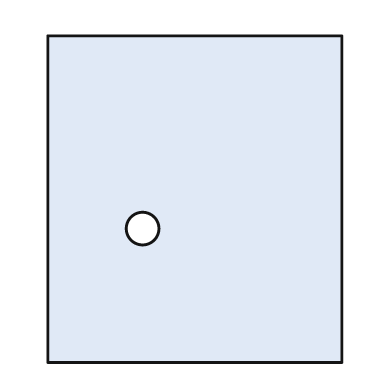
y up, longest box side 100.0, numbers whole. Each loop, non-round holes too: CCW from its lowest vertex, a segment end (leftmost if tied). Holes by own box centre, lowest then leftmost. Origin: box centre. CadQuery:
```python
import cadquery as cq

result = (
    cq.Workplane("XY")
    .moveTo(-45.0, -50.0)
    .lineTo(45.0, -50.0)
    .lineTo(45.0, 50.0)
    .lineTo(-45.0, 50.0)
    .close()
    .moveTo(-16.0, -9.0)
    .circle(5.0)
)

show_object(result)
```